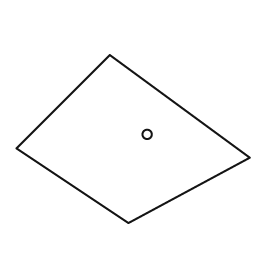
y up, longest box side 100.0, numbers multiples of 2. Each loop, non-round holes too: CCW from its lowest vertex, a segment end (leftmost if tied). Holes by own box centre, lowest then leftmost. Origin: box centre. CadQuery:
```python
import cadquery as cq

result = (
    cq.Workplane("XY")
    .moveTo(-2.0, -36.0)
    .lineTo(50.0, -8.0)
    .lineTo(-10.0, 36.0)
    .lineTo(-50.0, -4.0)
    .close()
    .moveTo(6.0, 2.0)
    .circle(2.0)
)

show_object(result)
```